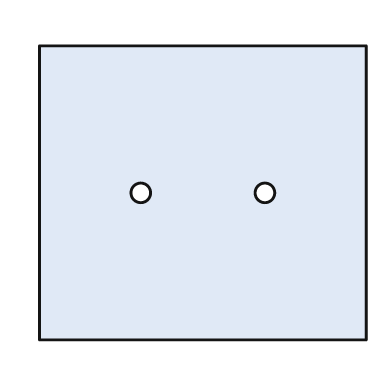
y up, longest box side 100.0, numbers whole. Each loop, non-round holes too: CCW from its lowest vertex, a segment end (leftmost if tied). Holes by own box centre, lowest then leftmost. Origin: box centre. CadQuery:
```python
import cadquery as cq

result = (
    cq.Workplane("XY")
    .moveTo(-50.0, -45.0)
    .lineTo(50.0, -45.0)
    .lineTo(50.0, 45.0)
    .lineTo(-50.0, 45.0)
    .close()
    .moveTo(-19.0, 0.0)
    .circle(3.0)
    .moveTo(19.0, 0.0)
    .circle(3.0)
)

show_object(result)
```